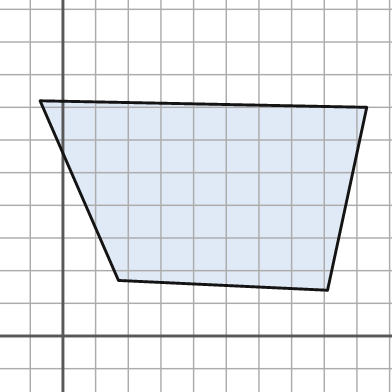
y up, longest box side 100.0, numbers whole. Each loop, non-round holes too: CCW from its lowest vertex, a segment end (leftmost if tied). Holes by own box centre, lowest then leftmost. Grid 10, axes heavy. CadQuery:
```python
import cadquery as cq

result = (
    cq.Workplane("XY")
    .moveTo(81.0, 14.0)
    .lineTo(93.0, 70.0)
    .lineTo(-7.0, 72.0)
    .lineTo(17.0, 17.0)
    .close()
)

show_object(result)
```